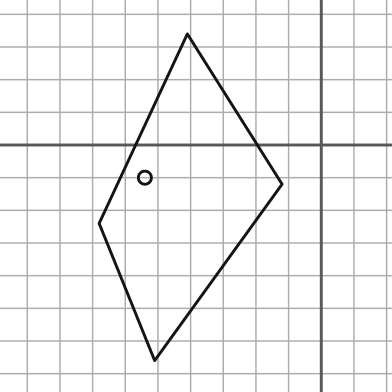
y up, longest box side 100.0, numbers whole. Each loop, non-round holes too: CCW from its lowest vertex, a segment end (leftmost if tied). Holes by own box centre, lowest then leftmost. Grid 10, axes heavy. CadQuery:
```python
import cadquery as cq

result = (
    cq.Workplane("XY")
    .moveTo(-51.0, -66.0)
    .lineTo(-12.0, -12.0)
    .lineTo(-41.0, 34.0)
    .lineTo(-68.0, -24.0)
    .close()
    .moveTo(-54.0, -10.0)
    .circle(2.0)
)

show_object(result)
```